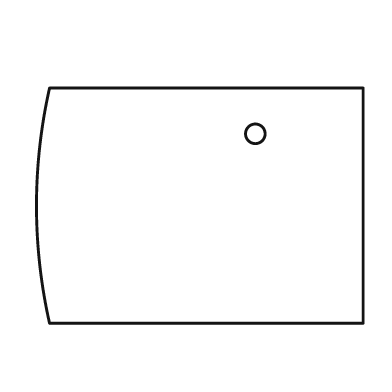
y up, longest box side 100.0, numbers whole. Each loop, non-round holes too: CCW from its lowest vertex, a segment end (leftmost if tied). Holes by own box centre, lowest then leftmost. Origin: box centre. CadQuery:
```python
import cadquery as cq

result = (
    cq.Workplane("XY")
    .moveTo(-46.0, -36.0)
    .lineTo(50.0, -36.0)
    .lineTo(50.0, 36.0)
    .lineTo(-46.0, 36.0)
    .threePointArc((-50.0, 0.0), (-46.0, -36.0))
    .close()
    .moveTo(17.0, 22.0)
    .circle(3.0)
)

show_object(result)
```